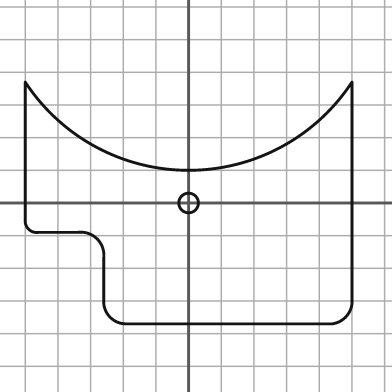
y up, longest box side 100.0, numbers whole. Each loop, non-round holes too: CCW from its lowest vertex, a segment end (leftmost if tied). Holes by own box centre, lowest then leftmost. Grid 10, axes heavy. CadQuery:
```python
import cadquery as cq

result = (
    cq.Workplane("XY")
    .moveTo(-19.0, -37.0)
    .lineTo(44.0, -37.0)
    .threePointArc((48.0, -35.0), (50.0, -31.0))
    .lineTo(50.0, 37.0)
    .threePointArc((0.0, 10.0), (-50.0, 37.0))
    .lineTo(-50.0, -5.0)
    .threePointArc((-49.0, -8.0), (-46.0, -9.0))
    .lineTo(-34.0, -9.0)
    .threePointArc((-28.0, -11.0), (-26.0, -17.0))
    .lineTo(-26.0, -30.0)
    .threePointArc((-24.0, -35.0), (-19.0, -37.0))
    .close()
    .moveTo(0.0, 0.0)
    .circle(3.0)
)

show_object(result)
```